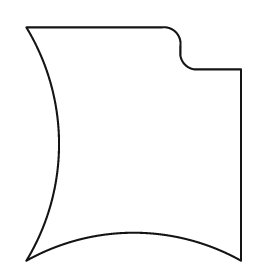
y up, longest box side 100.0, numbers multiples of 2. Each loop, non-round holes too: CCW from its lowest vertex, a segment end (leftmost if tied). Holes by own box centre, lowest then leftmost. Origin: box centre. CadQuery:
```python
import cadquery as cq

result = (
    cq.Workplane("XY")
    .moveTo(-46.0, -50.0)
    .threePointArc((0.0, -38.0), (46.0, -50.0))
    .lineTo(46.0, 32.0)
    .lineTo(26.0, 32.0)
    .threePointArc((22.0, 34.0), (20.0, 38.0))
    .lineTo(20.0, 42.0)
    .threePointArc((18.0, 48.0), (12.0, 50.0))
    .lineTo(-46.0, 50.0)
    .threePointArc((-32.0, 0.0), (-46.0, -50.0))
    .close()
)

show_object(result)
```